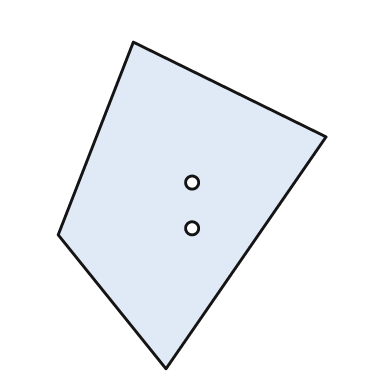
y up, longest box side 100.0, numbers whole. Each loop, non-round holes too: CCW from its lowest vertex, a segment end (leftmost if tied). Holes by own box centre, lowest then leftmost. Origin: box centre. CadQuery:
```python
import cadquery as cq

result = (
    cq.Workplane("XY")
    .moveTo(-8.0, -50.0)
    .lineTo(41.0, 21.0)
    .lineTo(-18.0, 50.0)
    .lineTo(-41.0, -9.0)
    .close()
    .moveTo(0.0, -7.0)
    .circle(2.0)
    .moveTo(0.0, 7.0)
    .circle(2.0)
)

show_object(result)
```